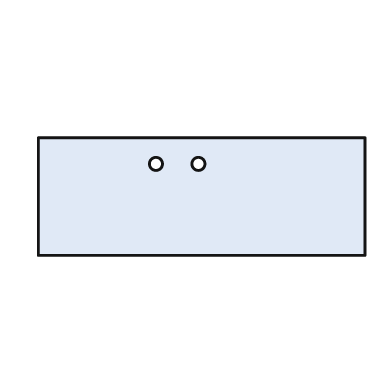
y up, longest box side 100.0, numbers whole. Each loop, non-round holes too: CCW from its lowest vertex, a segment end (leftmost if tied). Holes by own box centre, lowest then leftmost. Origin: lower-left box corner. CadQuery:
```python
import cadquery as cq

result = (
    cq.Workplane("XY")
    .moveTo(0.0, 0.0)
    .lineTo(100.0, 0.0)
    .lineTo(100.0, 36.0)
    .lineTo(0.0, 36.0)
    .close()
    .moveTo(36.0, 28.0)
    .circle(2.0)
    .moveTo(49.0, 28.0)
    .circle(2.0)
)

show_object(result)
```